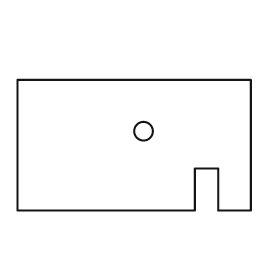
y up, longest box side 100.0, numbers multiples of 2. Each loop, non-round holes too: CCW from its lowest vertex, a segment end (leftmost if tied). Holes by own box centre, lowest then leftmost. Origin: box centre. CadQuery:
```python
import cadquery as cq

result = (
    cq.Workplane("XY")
    .moveTo(-50.0, -28.0)
    .lineTo(26.0, -28.0)
    .lineTo(26.0, -10.0)
    .lineTo(36.0, -10.0)
    .lineTo(36.0, -28.0)
    .lineTo(50.0, -28.0)
    .lineTo(50.0, 28.0)
    .lineTo(-50.0, 28.0)
    .close()
    .moveTo(4.0, 6.0)
    .circle(4.0)
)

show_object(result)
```